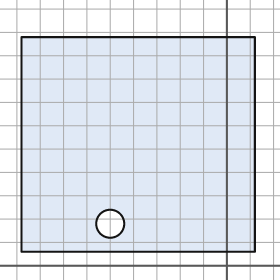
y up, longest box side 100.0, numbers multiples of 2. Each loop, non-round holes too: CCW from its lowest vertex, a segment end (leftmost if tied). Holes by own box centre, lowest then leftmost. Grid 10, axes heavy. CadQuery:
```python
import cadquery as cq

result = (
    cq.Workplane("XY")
    .moveTo(-88.0, 6.0)
    .lineTo(12.0, 6.0)
    .lineTo(12.0, 98.0)
    .lineTo(-88.0, 98.0)
    .close()
    .moveTo(-50.0, 18.0)
    .circle(6.0)
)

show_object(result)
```